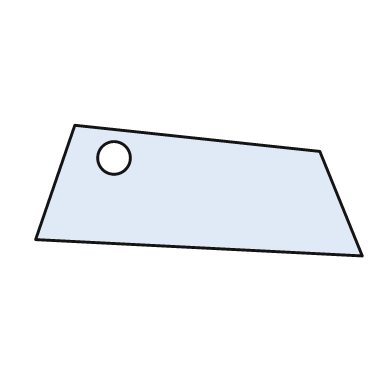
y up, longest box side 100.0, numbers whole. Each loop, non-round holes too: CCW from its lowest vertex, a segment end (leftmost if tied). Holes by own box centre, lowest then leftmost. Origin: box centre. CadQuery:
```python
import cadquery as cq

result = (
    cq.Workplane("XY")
    .moveTo(50.0, -20.0)
    .lineTo(37.0, 12.0)
    .lineTo(-38.0, 20.0)
    .lineTo(-50.0, -15.0)
    .close()
    .moveTo(-26.0, 10.0)
    .circle(5.0)
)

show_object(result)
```